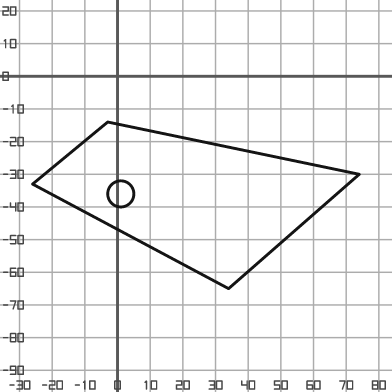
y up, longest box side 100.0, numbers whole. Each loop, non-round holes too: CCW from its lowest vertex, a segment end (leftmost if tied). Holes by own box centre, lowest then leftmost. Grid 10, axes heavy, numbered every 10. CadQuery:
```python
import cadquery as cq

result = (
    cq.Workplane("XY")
    .moveTo(34.0, -65.0)
    .lineTo(74.0, -30.0)
    .lineTo(-3.0, -14.0)
    .lineTo(-26.0, -33.0)
    .close()
    .moveTo(1.0, -36.0)
    .circle(4.0)
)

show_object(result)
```